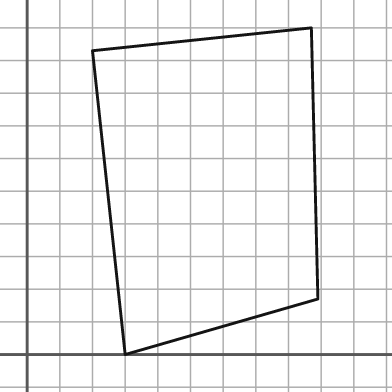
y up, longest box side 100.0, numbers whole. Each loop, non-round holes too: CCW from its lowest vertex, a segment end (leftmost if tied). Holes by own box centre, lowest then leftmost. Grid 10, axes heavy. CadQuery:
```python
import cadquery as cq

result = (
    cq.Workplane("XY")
    .moveTo(30.0, 0.0)
    .lineTo(89.0, 17.0)
    .lineTo(87.0, 100.0)
    .lineTo(20.0, 93.0)
    .close()
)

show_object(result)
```